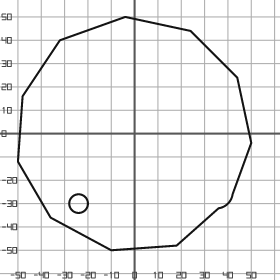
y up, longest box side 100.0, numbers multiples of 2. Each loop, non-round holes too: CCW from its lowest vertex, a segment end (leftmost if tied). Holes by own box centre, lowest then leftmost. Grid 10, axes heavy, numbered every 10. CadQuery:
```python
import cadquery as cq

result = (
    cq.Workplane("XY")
    .moveTo(-10.0, -50.0)
    .lineTo(18.0, -48.0)
    .lineTo(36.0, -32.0)
    .threePointArc((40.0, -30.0), (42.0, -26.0))
    .lineTo(50.0, -4.0)
    .lineTo(44.0, 24.0)
    .lineTo(24.0, 44.0)
    .lineTo(-4.0, 50.0)
    .lineTo(-32.0, 40.0)
    .lineTo(-48.0, 16.0)
    .lineTo(-50.0, -12.0)
    .lineTo(-36.0, -36.0)
    .close()
    .moveTo(-24.0, -30.0)
    .circle(4.0)
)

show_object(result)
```